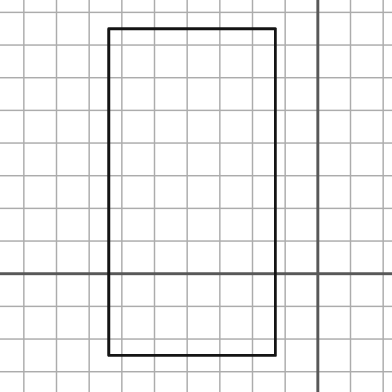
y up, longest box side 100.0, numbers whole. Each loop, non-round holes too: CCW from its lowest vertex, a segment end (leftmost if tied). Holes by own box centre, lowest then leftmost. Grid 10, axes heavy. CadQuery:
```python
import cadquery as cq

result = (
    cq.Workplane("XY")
    .moveTo(-64.0, -25.0)
    .lineTo(-13.0, -25.0)
    .lineTo(-13.0, 75.0)
    .lineTo(-64.0, 75.0)
    .close()
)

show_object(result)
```